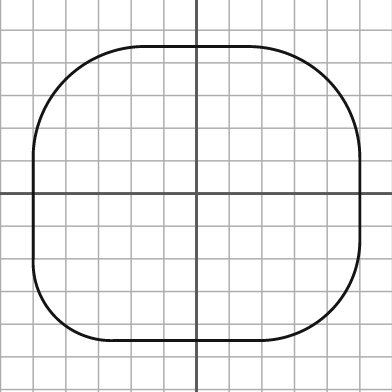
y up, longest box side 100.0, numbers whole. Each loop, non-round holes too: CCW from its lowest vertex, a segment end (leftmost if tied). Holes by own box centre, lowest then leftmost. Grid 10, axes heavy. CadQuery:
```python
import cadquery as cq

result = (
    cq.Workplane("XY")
    .moveTo(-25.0, -45.0)
    .lineTo(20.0, -45.0)
    .threePointArc((41.0, -36.0), (50.0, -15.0))
    .lineTo(50.0, 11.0)
    .threePointArc((40.0, 35.0), (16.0, 45.0))
    .lineTo(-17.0, 45.0)
    .threePointArc((-40.0, 35.0), (-50.0, 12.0))
    .lineTo(-50.0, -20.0)
    .threePointArc((-43.0, -38.0), (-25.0, -45.0))
    .close()
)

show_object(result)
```